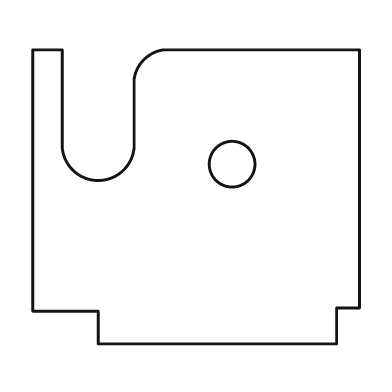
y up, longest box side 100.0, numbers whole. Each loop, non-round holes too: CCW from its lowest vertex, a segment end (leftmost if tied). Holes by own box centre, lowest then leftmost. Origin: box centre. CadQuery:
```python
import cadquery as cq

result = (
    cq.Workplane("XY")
    .moveTo(-30.0, -45.0)
    .lineTo(43.0, -45.0)
    .lineTo(43.0, -34.0)
    .lineTo(50.0, -34.0)
    .lineTo(50.0, 45.0)
    .lineTo(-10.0, 45.0)
    .threePointArc((-16.0, 42.0), (-19.0, 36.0))
    .lineTo(-19.0, 15.0)
    .threePointArc((-30.0, 5.0), (-41.0, 15.0))
    .lineTo(-41.0, 45.0)
    .lineTo(-50.0, 45.0)
    .lineTo(-50.0, -35.0)
    .lineTo(-30.0, -35.0)
    .close()
    .moveTo(11.0, 10.0)
    .circle(7.0)
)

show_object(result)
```